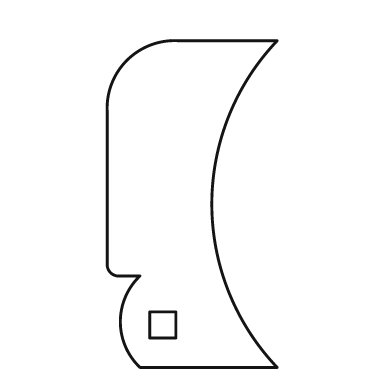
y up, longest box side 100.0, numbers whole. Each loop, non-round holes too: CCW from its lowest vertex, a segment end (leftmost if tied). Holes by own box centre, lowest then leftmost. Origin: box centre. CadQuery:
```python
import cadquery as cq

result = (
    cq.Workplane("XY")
    .moveTo(-16.0, -50.0)
    .lineTo(26.0, -50.0)
    .threePointArc((6.0, 0.0), (26.0, 50.0))
    .lineTo(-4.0, 50.0)
    .threePointArc((-20.0, 44.0), (-26.0, 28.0))
    .lineTo(-26.0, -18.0)
    .threePointArc((-25.0, -21.0), (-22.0, -22.0))
    .lineTo(-16.0, -22.0)
    .threePointArc((-22.0, -36.0), (-16.0, -50.0))
    .close()
    .moveTo(-13.0, -41.0)
    .lineTo(-5.0, -41.0)
    .lineTo(-5.0, -33.0)
    .lineTo(-13.0, -33.0)
    .close()
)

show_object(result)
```